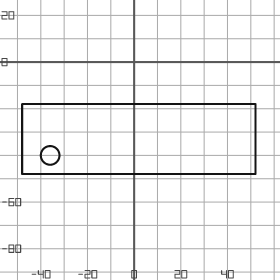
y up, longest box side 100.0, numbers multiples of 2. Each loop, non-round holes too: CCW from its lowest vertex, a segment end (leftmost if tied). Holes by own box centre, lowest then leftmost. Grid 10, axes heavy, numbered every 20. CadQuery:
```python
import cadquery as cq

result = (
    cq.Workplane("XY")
    .moveTo(-48.0, -48.0)
    .lineTo(52.0, -48.0)
    .lineTo(52.0, -18.0)
    .lineTo(-48.0, -18.0)
    .close()
    .moveTo(-36.0, -40.0)
    .circle(4.0)
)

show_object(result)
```